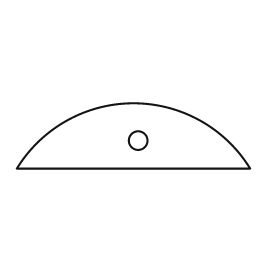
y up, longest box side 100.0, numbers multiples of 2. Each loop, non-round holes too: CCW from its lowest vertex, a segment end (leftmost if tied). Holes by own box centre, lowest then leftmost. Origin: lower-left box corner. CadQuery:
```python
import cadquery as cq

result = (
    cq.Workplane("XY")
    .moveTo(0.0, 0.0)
    .lineTo(100.0, 0.0)
    .threePointArc((50.0, 28.0), (0.0, 0.0))
    .close()
    .moveTo(52.0, 12.0)
    .circle(4.0)
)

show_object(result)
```